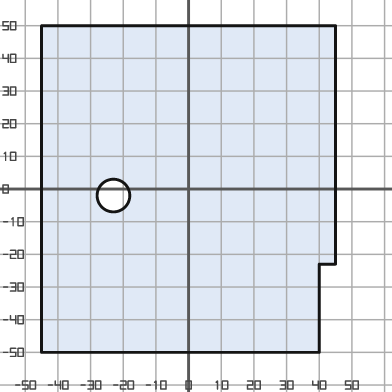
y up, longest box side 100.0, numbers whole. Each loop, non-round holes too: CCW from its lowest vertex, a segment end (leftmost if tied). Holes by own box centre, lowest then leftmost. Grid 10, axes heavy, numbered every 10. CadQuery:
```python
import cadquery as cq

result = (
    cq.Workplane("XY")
    .moveTo(-45.0, -50.0)
    .lineTo(40.0, -50.0)
    .lineTo(40.0, -23.0)
    .lineTo(45.0, -23.0)
    .lineTo(45.0, 50.0)
    .lineTo(-45.0, 50.0)
    .close()
    .moveTo(-23.0, -2.0)
    .circle(5.0)
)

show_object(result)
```